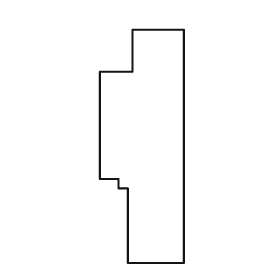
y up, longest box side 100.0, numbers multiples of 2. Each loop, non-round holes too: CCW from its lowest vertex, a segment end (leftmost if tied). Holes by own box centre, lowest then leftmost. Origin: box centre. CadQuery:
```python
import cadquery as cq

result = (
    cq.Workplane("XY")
    .moveTo(-6.0, -50.0)
    .lineTo(18.0, -50.0)
    .lineTo(18.0, 50.0)
    .lineTo(-4.0, 50.0)
    .lineTo(-4.0, 32.0)
    .lineTo(-18.0, 32.0)
    .lineTo(-18.0, -14.0)
    .lineTo(-10.0, -14.0)
    .lineTo(-10.0, -18.0)
    .lineTo(-6.0, -18.0)
    .close()
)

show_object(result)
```